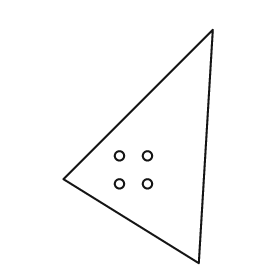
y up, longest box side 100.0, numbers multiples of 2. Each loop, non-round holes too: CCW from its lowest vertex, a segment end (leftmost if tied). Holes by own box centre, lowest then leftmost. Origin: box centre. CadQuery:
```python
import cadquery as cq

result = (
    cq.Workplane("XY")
    .moveTo(26.0, -50.0)
    .lineTo(32.0, 50.0)
    .lineTo(-32.0, -14.0)
    .close()
    .moveTo(-8.0, -16.0)
    .circle(2.0)
    .moveTo(4.0, -16.0)
    .circle(2.0)
    .moveTo(-8.0, -4.0)
    .circle(2.0)
    .moveTo(4.0, -4.0)
    .circle(2.0)
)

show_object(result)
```